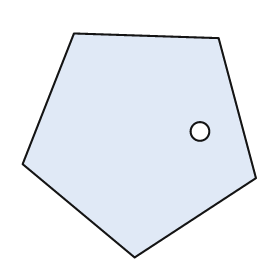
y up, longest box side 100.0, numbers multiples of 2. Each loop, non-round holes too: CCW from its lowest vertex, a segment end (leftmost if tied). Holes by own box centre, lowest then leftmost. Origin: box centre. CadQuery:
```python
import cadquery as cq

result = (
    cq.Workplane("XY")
    .moveTo(-2.0, -48.0)
    .lineTo(50.0, -14.0)
    .lineTo(34.0, 46.0)
    .lineTo(-28.0, 48.0)
    .lineTo(-50.0, -8.0)
    .close()
    .moveTo(26.0, 6.0)
    .circle(4.0)
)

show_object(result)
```